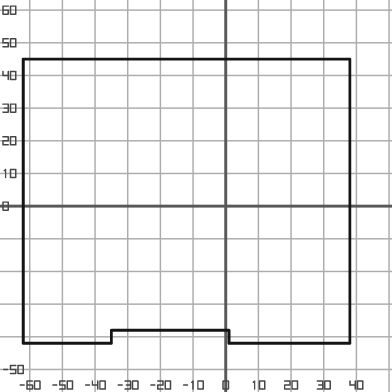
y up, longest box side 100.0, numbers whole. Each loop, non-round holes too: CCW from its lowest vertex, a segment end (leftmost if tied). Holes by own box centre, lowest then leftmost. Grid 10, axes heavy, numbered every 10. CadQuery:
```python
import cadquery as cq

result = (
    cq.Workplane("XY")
    .moveTo(-62.0, -42.0)
    .lineTo(-35.0, -42.0)
    .lineTo(-35.0, -38.0)
    .lineTo(1.0, -38.0)
    .lineTo(1.0, -42.0)
    .lineTo(38.0, -42.0)
    .lineTo(38.0, 45.0)
    .lineTo(-62.0, 45.0)
    .close()
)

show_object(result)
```